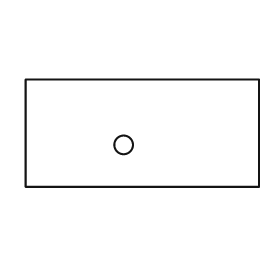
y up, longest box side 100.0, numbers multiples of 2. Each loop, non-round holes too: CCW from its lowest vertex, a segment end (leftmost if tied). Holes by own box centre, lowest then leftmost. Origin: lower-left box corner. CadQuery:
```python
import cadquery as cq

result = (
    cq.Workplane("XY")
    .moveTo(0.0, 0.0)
    .lineTo(100.0, 0.0)
    .lineTo(100.0, 46.0)
    .lineTo(0.0, 46.0)
    .close()
    .moveTo(42.0, 18.0)
    .circle(4.0)
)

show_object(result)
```